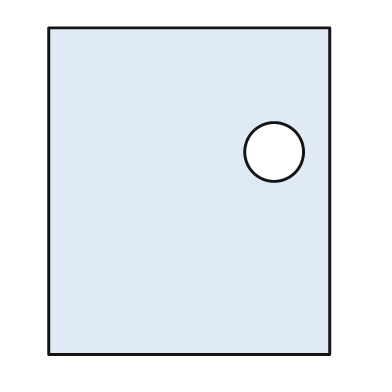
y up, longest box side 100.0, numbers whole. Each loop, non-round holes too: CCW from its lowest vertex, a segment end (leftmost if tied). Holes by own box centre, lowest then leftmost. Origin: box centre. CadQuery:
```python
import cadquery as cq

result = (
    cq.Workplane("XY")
    .moveTo(-43.0, -50.0)
    .lineTo(43.0, -50.0)
    .lineTo(43.0, 50.0)
    .lineTo(-43.0, 50.0)
    .close()
    .moveTo(26.0, 12.0)
    .circle(9.0)
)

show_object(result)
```